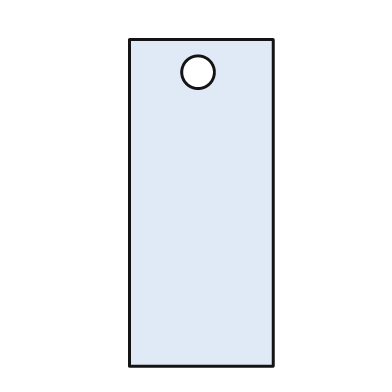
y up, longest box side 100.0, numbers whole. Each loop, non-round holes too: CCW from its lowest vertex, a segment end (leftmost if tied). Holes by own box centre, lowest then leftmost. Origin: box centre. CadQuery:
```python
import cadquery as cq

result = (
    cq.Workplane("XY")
    .moveTo(-22.0, -50.0)
    .lineTo(22.0, -50.0)
    .lineTo(22.0, 50.0)
    .lineTo(-22.0, 50.0)
    .close()
    .moveTo(-1.0, 40.0)
    .circle(5.0)
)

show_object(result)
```